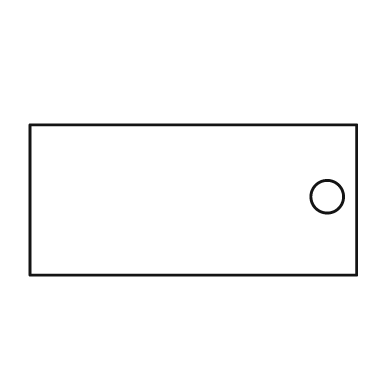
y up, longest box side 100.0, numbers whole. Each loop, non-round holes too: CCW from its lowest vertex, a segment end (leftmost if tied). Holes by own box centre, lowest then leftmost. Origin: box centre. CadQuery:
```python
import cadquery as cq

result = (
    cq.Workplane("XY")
    .moveTo(-50.0, -23.0)
    .lineTo(50.0, -23.0)
    .lineTo(50.0, 23.0)
    .lineTo(-50.0, 23.0)
    .close()
    .moveTo(41.0, 1.0)
    .circle(5.0)
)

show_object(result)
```